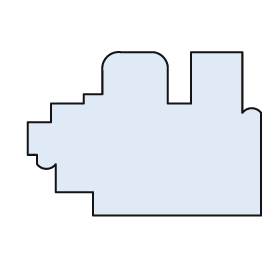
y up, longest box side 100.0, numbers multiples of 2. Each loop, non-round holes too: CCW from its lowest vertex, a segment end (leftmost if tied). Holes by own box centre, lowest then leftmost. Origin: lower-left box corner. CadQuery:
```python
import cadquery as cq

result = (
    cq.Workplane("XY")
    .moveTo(28.0, 0.0)
    .lineTo(100.0, 0.0)
    .lineTo(100.0, 44.0)
    .threePointArc((96.0, 46.0), (92.0, 44.0))
    .lineTo(92.0, 70.0)
    .lineTo(70.0, 70.0)
    .lineTo(70.0, 48.0)
    .lineTo(60.0, 48.0)
    .lineTo(60.0, 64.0)
    .threePointArc((58.0, 68.0), (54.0, 70.0))
    .lineTo(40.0, 70.0)
    .threePointArc((34.0, 68.0), (32.0, 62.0))
    .lineTo(32.0, 52.0)
    .lineTo(24.0, 52.0)
    .lineTo(24.0, 48.0)
    .lineTo(10.0, 48.0)
    .lineTo(10.0, 40.0)
    .lineTo(0.0, 40.0)
    .lineTo(0.0, 26.0)
    .lineTo(4.0, 26.0)
    .lineTo(4.0, 22.0)
    .threePointArc((8.0, 20.0), (12.0, 22.0))
    .lineTo(12.0, 10.0)
    .lineTo(28.0, 10.0)
    .close()
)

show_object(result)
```